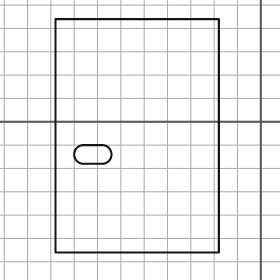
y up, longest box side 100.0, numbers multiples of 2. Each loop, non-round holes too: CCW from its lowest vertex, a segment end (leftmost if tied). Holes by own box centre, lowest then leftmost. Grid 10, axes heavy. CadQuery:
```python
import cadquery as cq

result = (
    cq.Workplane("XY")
    .moveTo(-88.0, -56.0)
    .lineTo(-18.0, -56.0)
    .lineTo(-18.0, 44.0)
    .lineTo(-88.0, 44.0)
    .close()
    .moveTo(-76.0, -18.0)
    .lineTo(-68.0, -18.0)
    .threePointArc((-64.0, -14.0), (-68.0, -10.0))
    .lineTo(-76.0, -10.0)
    .threePointArc((-80.0, -14.0), (-76.0, -18.0))
    .close()
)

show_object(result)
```